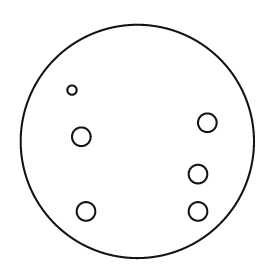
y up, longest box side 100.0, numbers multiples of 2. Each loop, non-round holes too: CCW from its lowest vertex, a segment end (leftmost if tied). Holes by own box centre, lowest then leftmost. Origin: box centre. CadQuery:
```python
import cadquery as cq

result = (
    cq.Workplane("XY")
    .moveTo(0.0, 0.0)
    .circle(50.0)
    .moveTo(-22.0, -30.0)
    .circle(4.0)
    .moveTo(26.0, -30.0)
    .circle(4.0)
    .moveTo(26.0, -14.0)
    .circle(4.0)
    .moveTo(-24.0, 2.0)
    .circle(4.0)
    .moveTo(30.0, 8.0)
    .circle(4.0)
    .moveTo(-28.0, 22.0)
    .circle(2.0)
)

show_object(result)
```